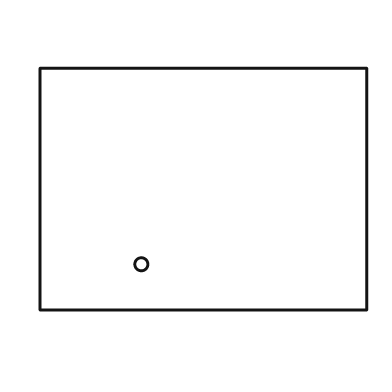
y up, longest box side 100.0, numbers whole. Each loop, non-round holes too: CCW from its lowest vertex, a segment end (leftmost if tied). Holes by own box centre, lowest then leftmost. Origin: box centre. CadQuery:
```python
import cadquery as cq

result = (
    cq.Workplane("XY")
    .moveTo(-50.0, -37.0)
    .lineTo(50.0, -37.0)
    .lineTo(50.0, 37.0)
    .lineTo(-50.0, 37.0)
    .close()
    .moveTo(-19.0, -23.0)
    .circle(2.0)
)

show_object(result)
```